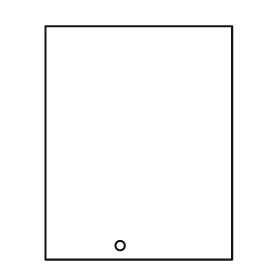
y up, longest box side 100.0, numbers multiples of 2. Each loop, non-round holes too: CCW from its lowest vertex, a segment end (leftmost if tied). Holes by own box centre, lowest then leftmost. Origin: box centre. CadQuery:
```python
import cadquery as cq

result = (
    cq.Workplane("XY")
    .moveTo(-40.0, -50.0)
    .lineTo(40.0, -50.0)
    .lineTo(40.0, 50.0)
    .lineTo(-40.0, 50.0)
    .close()
    .moveTo(-8.0, -44.0)
    .circle(2.0)
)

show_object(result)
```